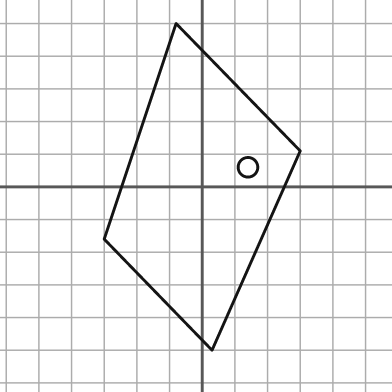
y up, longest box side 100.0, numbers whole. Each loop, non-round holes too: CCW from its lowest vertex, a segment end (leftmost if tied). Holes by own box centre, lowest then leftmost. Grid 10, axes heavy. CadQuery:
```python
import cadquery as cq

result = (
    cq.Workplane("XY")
    .moveTo(3.0, -50.0)
    .lineTo(30.0, 11.0)
    .lineTo(-8.0, 50.0)
    .lineTo(-30.0, -16.0)
    .close()
    .moveTo(14.0, 6.0)
    .circle(3.0)
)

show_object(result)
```